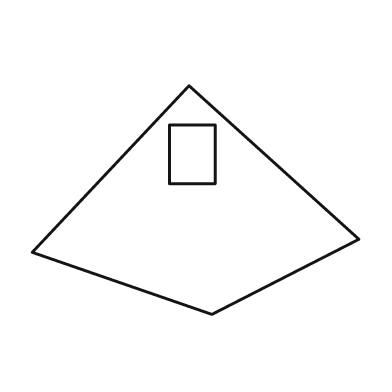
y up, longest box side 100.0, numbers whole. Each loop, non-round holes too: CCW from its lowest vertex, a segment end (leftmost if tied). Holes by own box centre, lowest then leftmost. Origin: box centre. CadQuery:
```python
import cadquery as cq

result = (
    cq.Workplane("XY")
    .moveTo(5.0, -35.0)
    .lineTo(50.0, -12.0)
    .lineTo(-2.0, 35.0)
    .lineTo(-50.0, -16.0)
    .close()
    .moveTo(-8.0, 5.0)
    .lineTo(6.0, 5.0)
    .lineTo(6.0, 23.0)
    .lineTo(-8.0, 23.0)
    .close()
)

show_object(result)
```